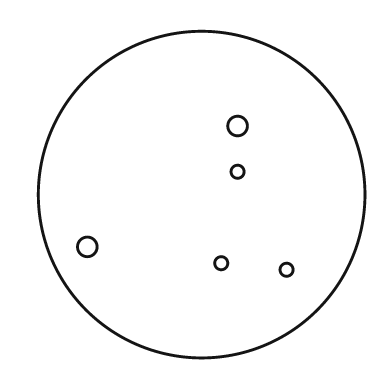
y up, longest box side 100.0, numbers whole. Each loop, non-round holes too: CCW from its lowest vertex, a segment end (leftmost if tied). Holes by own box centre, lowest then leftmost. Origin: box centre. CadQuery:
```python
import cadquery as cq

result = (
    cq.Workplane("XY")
    .moveTo(0.0, 0.0)
    .circle(50.0)
    .moveTo(26.0, -23.0)
    .circle(2.0)
    .moveTo(6.0, -21.0)
    .circle(2.0)
    .moveTo(-35.0, -16.0)
    .circle(3.0)
    .moveTo(11.0, 7.0)
    .circle(2.0)
    .moveTo(11.0, 21.0)
    .circle(3.0)
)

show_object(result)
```